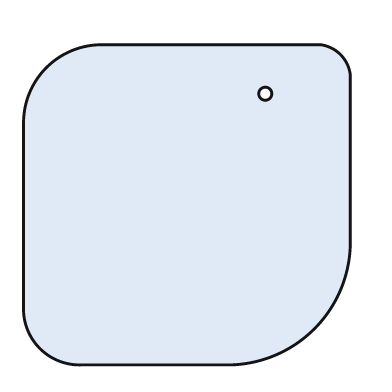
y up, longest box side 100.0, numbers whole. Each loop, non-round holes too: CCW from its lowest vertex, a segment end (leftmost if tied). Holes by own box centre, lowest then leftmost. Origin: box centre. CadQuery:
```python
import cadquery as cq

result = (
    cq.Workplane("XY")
    .moveTo(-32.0, -49.0)
    .lineTo(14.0, -49.0)
    .threePointArc((39.0, -38.0), (50.0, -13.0))
    .lineTo(50.0, 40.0)
    .threePointArc((47.0, 46.0), (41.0, 49.0))
    .lineTo(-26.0, 49.0)
    .threePointArc((-43.0, 42.0), (-50.0, 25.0))
    .lineTo(-50.0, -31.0)
    .threePointArc((-45.0, -44.0), (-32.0, -49.0))
    .close()
    .moveTo(24.0, 34.0)
    .circle(2.0)
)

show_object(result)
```